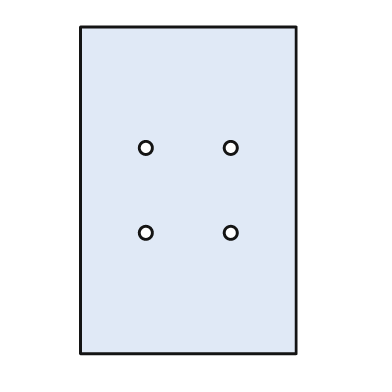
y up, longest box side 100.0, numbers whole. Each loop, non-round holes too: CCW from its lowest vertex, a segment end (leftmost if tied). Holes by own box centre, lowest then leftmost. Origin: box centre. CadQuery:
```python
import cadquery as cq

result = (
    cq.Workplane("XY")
    .moveTo(-33.0, -50.0)
    .lineTo(33.0, -50.0)
    .lineTo(33.0, 50.0)
    .lineTo(-33.0, 50.0)
    .close()
    .moveTo(-13.0, -13.0)
    .circle(2.0)
    .moveTo(13.0, -13.0)
    .circle(2.0)
    .moveTo(-13.0, 13.0)
    .circle(2.0)
    .moveTo(13.0, 13.0)
    .circle(2.0)
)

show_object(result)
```